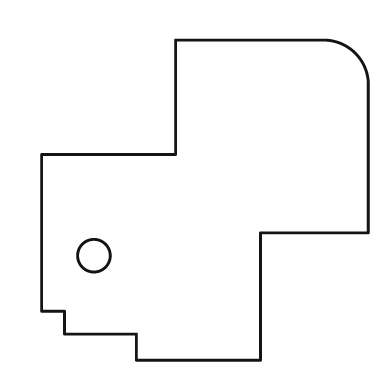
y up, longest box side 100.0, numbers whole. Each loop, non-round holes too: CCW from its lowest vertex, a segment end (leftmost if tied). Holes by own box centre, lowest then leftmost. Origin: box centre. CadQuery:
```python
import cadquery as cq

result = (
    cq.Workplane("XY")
    .moveTo(-21.0, -49.0)
    .lineTo(17.0, -49.0)
    .lineTo(17.0, -10.0)
    .lineTo(50.0, -10.0)
    .lineTo(50.0, 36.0)
    .threePointArc((46.0, 45.0), (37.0, 49.0))
    .lineTo(-9.0, 49.0)
    .lineTo(-9.0, 14.0)
    .lineTo(-50.0, 14.0)
    .lineTo(-50.0, -34.0)
    .lineTo(-43.0, -34.0)
    .lineTo(-43.0, -41.0)
    .lineTo(-21.0, -41.0)
    .close()
    .moveTo(-34.0, -17.0)
    .circle(5.0)
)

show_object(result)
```